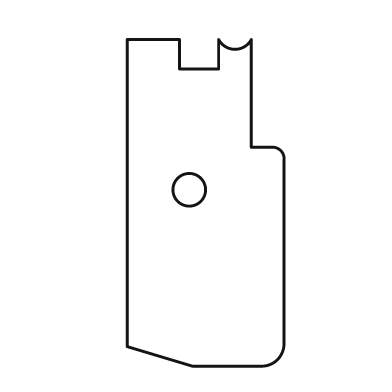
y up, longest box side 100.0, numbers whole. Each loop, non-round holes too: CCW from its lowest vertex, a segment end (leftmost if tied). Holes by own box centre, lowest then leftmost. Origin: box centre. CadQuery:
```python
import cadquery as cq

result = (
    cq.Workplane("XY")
    .moveTo(-4.0, -50.0)
    .lineTo(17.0, -50.0)
    .threePointArc((22.0, -48.0), (24.0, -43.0))
    .lineTo(24.0, 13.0)
    .threePointArc((23.0, 16.0), (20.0, 17.0))
    .lineTo(14.0, 17.0)
    .lineTo(14.0, 50.0)
    .threePointArc((9.0, 47.0), (4.0, 50.0))
    .lineTo(4.0, 41.0)
    .lineTo(-8.0, 41.0)
    .lineTo(-8.0, 50.0)
    .lineTo(-24.0, 50.0)
    .lineTo(-24.0, -44.0)
    .close()
    .moveTo(-5.0, 4.0)
    .circle(5.0)
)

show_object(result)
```